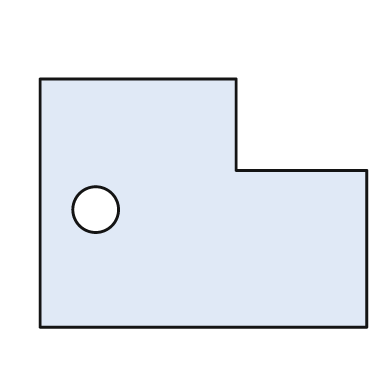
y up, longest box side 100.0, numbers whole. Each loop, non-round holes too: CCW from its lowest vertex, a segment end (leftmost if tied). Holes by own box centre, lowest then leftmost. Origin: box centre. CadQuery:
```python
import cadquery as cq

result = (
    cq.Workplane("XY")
    .moveTo(-50.0, -38.0)
    .lineTo(50.0, -38.0)
    .lineTo(50.0, 10.0)
    .lineTo(10.0, 10.0)
    .lineTo(10.0, 38.0)
    .lineTo(-50.0, 38.0)
    .close()
    .moveTo(-33.0, -2.0)
    .circle(7.0)
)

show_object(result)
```